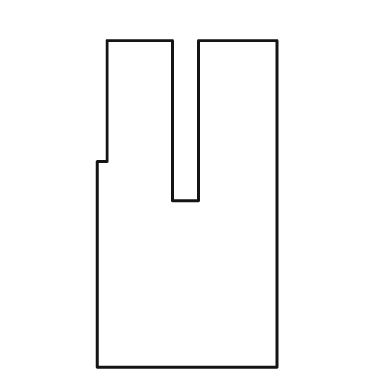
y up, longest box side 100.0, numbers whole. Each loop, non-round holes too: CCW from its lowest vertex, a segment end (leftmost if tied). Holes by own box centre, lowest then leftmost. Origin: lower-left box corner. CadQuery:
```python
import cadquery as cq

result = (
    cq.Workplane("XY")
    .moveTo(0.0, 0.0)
    .lineTo(55.0, 0.0)
    .lineTo(55.0, 100.0)
    .lineTo(31.0, 100.0)
    .lineTo(31.0, 51.0)
    .lineTo(23.0, 51.0)
    .lineTo(23.0, 100.0)
    .lineTo(3.0, 100.0)
    .lineTo(3.0, 63.0)
    .lineTo(0.0, 63.0)
    .close()
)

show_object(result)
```